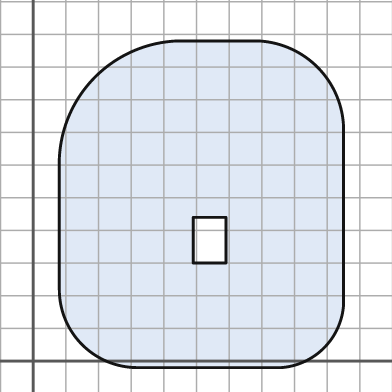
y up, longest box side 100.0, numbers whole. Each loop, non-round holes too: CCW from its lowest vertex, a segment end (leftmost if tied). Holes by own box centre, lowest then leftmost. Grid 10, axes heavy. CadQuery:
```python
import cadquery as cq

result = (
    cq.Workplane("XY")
    .moveTo(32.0, -2.0)
    .lineTo(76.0, -2.0)
    .threePointArc((89.0, 4.0), (95.0, 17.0))
    .lineTo(95.0, 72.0)
    .threePointArc((87.0, 90.0), (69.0, 98.0))
    .lineTo(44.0, 98.0)
    .threePointArc((19.0, 87.0), (8.0, 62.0))
    .lineTo(8.0, 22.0)
    .threePointArc((15.0, 5.0), (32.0, -2.0))
    .close()
    .moveTo(49.0, 30.0)
    .lineTo(59.0, 30.0)
    .lineTo(59.0, 44.0)
    .lineTo(49.0, 44.0)
    .close()
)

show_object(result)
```